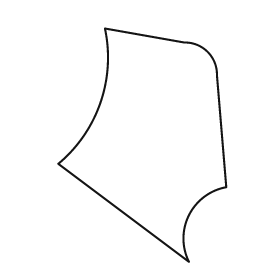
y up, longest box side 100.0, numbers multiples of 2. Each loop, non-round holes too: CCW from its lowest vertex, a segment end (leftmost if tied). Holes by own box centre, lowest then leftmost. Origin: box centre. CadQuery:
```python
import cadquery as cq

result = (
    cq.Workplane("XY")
    .moveTo(20.0, -50.0)
    .threePointArc((20.0, -30.0), (36.0, -18.0))
    .lineTo(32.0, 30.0)
    .threePointArc((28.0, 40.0), (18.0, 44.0))
    .lineTo(-16.0, 50.0)
    .threePointArc((-18.0, 18.0), (-36.0, -8.0))
    .close()
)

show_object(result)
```